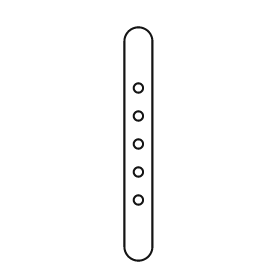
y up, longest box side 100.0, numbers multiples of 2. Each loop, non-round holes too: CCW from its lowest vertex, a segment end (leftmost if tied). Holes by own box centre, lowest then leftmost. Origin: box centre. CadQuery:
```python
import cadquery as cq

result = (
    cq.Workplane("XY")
    .moveTo(-6.0, -44.0)
    .threePointArc((0.0, -50.0), (6.0, -44.0))
    .lineTo(6.0, 44.0)
    .threePointArc((0.0, 50.0), (-6.0, 44.0))
    .close()
    .moveTo(0.0, -24.0)
    .circle(2.0)
    .moveTo(0.0, -12.0)
    .circle(2.0)
    .moveTo(0.0, 0.0)
    .circle(2.0)
    .moveTo(0.0, 12.0)
    .circle(2.0)
    .moveTo(0.0, 24.0)
    .circle(2.0)
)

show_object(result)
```